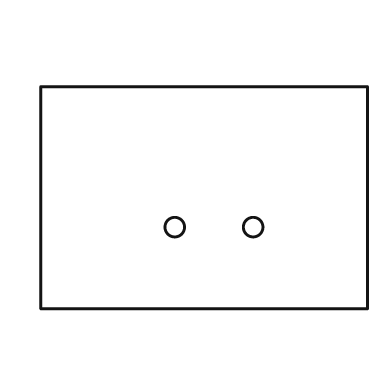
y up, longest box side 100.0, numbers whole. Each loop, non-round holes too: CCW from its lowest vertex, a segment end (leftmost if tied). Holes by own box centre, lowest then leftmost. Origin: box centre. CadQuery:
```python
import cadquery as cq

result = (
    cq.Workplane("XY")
    .moveTo(-50.0, -34.0)
    .lineTo(50.0, -34.0)
    .lineTo(50.0, 34.0)
    .lineTo(-50.0, 34.0)
    .close()
    .moveTo(-9.0, -9.0)
    .circle(3.0)
    .moveTo(15.0, -9.0)
    .circle(3.0)
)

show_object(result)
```